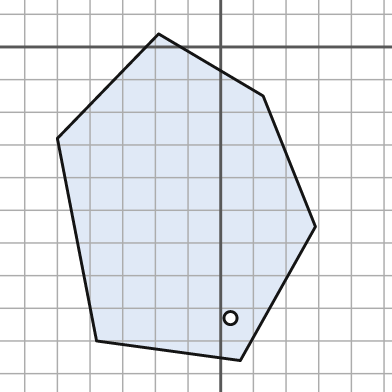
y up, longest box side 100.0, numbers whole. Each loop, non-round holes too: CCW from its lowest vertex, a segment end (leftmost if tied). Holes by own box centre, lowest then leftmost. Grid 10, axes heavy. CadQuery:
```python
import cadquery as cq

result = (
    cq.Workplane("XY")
    .moveTo(6.0, -96.0)
    .lineTo(29.0, -55.0)
    .lineTo(13.0, -15.0)
    .lineTo(-19.0, 4.0)
    .lineTo(-50.0, -28.0)
    .lineTo(-38.0, -90.0)
    .close()
    .moveTo(3.0, -83.0)
    .circle(2.0)
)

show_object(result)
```